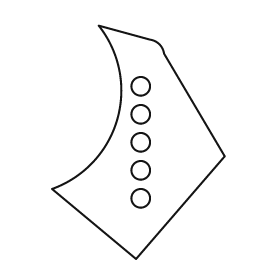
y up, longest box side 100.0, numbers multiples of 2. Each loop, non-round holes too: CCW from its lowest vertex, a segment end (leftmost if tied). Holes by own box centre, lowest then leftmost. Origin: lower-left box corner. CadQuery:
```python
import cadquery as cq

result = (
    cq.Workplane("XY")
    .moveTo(36.0, 0.0)
    .lineTo(74.0, 44.0)
    .lineTo(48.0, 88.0)
    .threePointArc((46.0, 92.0), (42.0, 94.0))
    .lineTo(20.0, 100.0)
    .threePointArc((28.0, 60.0), (0.0, 30.0))
    .close()
    .moveTo(38.0, 26.0)
    .circle(4.0)
    .moveTo(38.0, 38.0)
    .circle(4.0)
    .moveTo(38.0, 50.0)
    .circle(4.0)
    .moveTo(38.0, 62.0)
    .circle(4.0)
    .moveTo(38.0, 74.0)
    .circle(4.0)
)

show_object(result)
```